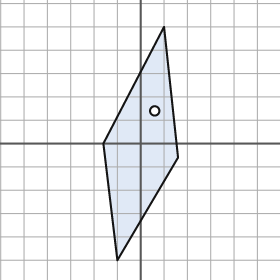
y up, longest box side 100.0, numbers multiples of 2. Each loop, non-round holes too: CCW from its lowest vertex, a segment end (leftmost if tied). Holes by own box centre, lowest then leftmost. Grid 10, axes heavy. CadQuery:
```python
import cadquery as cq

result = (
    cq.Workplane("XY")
    .moveTo(-10.0, -50.0)
    .lineTo(16.0, -6.0)
    .lineTo(10.0, 50.0)
    .lineTo(-16.0, 0.0)
    .close()
    .moveTo(6.0, 14.0)
    .circle(2.0)
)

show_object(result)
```